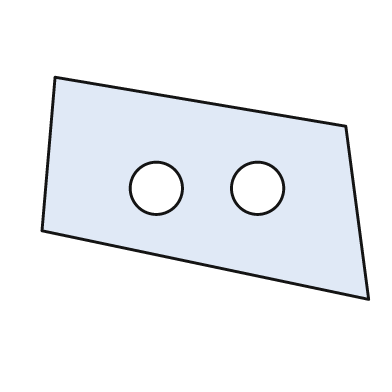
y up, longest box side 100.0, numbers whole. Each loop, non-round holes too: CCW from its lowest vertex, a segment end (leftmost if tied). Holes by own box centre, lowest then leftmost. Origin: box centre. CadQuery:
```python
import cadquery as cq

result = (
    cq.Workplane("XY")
    .moveTo(50.0, -34.0)
    .lineTo(43.0, 19.0)
    .lineTo(-46.0, 34.0)
    .lineTo(-50.0, -13.0)
    .close()
    .moveTo(-15.0, 0.0)
    .circle(8.0)
    .moveTo(16.0, 0.0)
    .circle(8.0)
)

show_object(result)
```